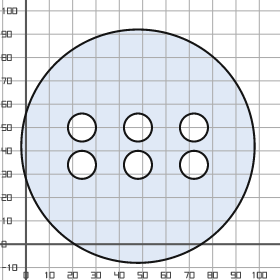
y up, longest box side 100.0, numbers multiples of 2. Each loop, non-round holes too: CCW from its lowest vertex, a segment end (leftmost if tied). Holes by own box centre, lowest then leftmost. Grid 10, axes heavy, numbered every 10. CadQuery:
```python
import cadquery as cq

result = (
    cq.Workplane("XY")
    .moveTo(48.0, 42.0)
    .circle(50.0)
    .moveTo(24.0, 34.0)
    .circle(6.0)
    .moveTo(48.0, 34.0)
    .circle(6.0)
    .moveTo(72.0, 34.0)
    .circle(6.0)
    .moveTo(24.0, 50.0)
    .circle(6.0)
    .moveTo(48.0, 50.0)
    .circle(6.0)
    .moveTo(72.0, 50.0)
    .circle(6.0)
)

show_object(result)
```